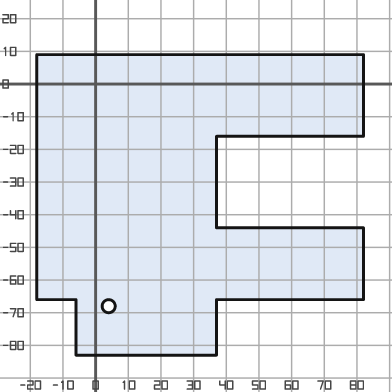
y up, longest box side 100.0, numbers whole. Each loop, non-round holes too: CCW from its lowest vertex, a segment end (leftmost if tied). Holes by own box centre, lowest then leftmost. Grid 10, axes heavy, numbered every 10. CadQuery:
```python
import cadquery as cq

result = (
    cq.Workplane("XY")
    .moveTo(-6.0, -83.0)
    .lineTo(37.0, -83.0)
    .lineTo(37.0, -66.0)
    .lineTo(82.0, -66.0)
    .lineTo(82.0, -44.0)
    .lineTo(37.0, -44.0)
    .lineTo(37.0, -16.0)
    .lineTo(82.0, -16.0)
    .lineTo(82.0, 9.0)
    .lineTo(-18.0, 9.0)
    .lineTo(-18.0, -66.0)
    .lineTo(-6.0, -66.0)
    .close()
    .moveTo(4.0, -68.0)
    .circle(2.0)
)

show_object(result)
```